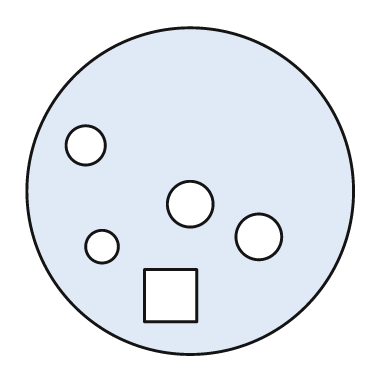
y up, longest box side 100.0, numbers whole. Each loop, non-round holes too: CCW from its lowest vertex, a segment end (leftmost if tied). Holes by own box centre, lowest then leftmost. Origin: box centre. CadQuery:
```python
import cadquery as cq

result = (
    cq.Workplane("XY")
    .moveTo(0.0, 0.0)
    .circle(50.0)
    .moveTo(-14.0, -40.0)
    .lineTo(2.0, -40.0)
    .lineTo(2.0, -24.0)
    .lineTo(-14.0, -24.0)
    .close()
    .moveTo(-27.0, -17.0)
    .circle(5.0)
    .moveTo(21.0, -14.0)
    .circle(7.0)
    .moveTo(0.0, -4.0)
    .circle(7.0)
    .moveTo(-32.0, 14.0)
    .circle(6.0)
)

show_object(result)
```